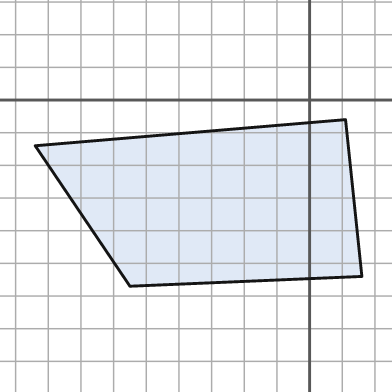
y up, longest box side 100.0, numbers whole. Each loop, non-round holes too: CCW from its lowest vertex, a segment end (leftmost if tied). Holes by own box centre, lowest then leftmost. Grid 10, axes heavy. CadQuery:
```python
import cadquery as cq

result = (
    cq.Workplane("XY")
    .moveTo(-55.0, -57.0)
    .lineTo(16.0, -54.0)
    .lineTo(11.0, -6.0)
    .lineTo(-84.0, -14.0)
    .close()
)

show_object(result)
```